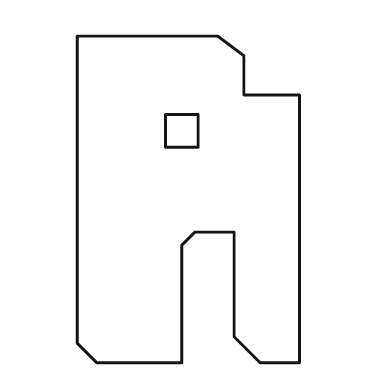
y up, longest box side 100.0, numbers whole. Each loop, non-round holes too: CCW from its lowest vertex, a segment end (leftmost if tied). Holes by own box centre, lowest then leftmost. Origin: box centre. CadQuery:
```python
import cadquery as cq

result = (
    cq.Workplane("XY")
    .moveTo(-28.0, -50.0)
    .lineTo(-2.0, -50.0)
    .lineTo(-2.0, -14.0)
    .lineTo(2.0, -10.0)
    .lineTo(14.0, -10.0)
    .lineTo(14.0, -42.0)
    .lineTo(22.0, -50.0)
    .lineTo(34.0, -50.0)
    .lineTo(34.0, 32.0)
    .lineTo(17.0, 32.0)
    .lineTo(17.0, 44.0)
    .lineTo(9.0, 50.0)
    .lineTo(-34.0, 50.0)
    .lineTo(-34.0, -44.0)
    .close()
    .moveTo(-7.0, 16.0)
    .lineTo(3.0, 16.0)
    .lineTo(3.0, 26.0)
    .lineTo(-7.0, 26.0)
    .close()
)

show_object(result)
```